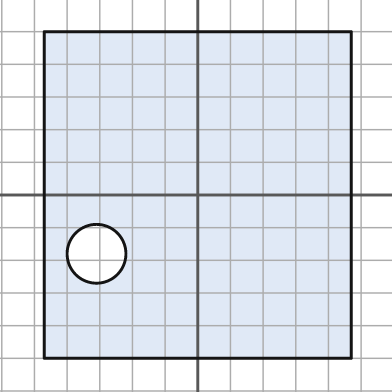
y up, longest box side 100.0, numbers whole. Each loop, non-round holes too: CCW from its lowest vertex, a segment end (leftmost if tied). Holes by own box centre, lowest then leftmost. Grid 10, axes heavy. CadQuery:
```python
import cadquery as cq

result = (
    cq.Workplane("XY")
    .moveTo(-47.0, -50.0)
    .lineTo(47.0, -50.0)
    .lineTo(47.0, 50.0)
    .lineTo(-47.0, 50.0)
    .close()
    .moveTo(-31.0, -18.0)
    .circle(9.0)
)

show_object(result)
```